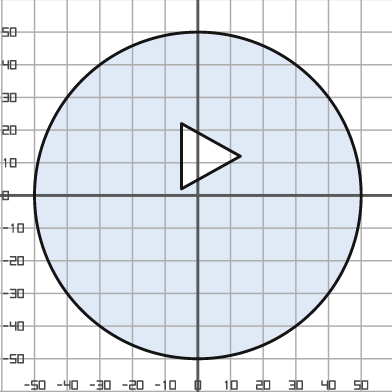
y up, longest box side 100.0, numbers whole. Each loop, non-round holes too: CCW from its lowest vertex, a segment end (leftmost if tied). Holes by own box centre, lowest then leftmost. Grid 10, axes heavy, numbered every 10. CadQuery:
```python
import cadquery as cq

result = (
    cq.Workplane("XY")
    .moveTo(0.0, 0.0)
    .circle(50.0)
    .moveTo(-5.0, 2.0)
    .lineTo(13.0, 12.0)
    .lineTo(-5.0, 22.0)
    .close()
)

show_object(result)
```